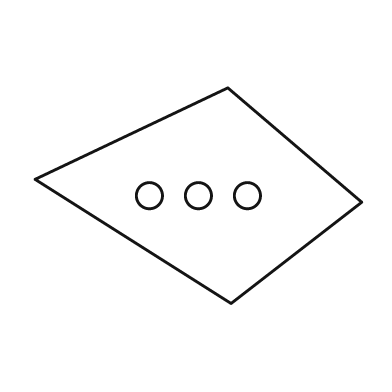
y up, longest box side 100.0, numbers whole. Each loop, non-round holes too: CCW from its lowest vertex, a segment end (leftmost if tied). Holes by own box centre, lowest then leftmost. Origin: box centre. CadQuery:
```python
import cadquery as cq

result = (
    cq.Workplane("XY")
    .moveTo(10.0, -33.0)
    .lineTo(50.0, -2.0)
    .lineTo(9.0, 33.0)
    .lineTo(-50.0, 5.0)
    .close()
    .moveTo(-15.0, 0.0)
    .circle(4.0)
    .moveTo(0.0, 0.0)
    .circle(4.0)
    .moveTo(15.0, 0.0)
    .circle(4.0)
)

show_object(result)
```